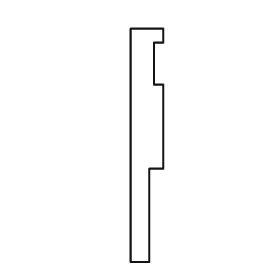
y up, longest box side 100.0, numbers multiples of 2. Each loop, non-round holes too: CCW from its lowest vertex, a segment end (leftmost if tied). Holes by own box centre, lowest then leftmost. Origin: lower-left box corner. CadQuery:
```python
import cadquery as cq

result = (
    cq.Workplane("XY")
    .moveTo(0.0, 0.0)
    .lineTo(8.0, 0.0)
    .lineTo(8.0, 40.0)
    .lineTo(14.0, 40.0)
    .lineTo(14.0, 76.0)
    .lineTo(10.0, 76.0)
    .lineTo(10.0, 94.0)
    .lineTo(14.0, 94.0)
    .lineTo(14.0, 100.0)
    .lineTo(0.0, 100.0)
    .close()
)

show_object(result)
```